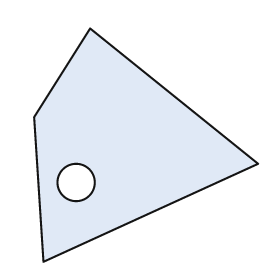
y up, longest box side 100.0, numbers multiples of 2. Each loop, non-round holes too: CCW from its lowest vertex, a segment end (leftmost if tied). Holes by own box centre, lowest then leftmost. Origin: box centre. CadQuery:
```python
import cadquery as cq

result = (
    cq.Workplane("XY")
    .moveTo(-44.0, -50.0)
    .lineTo(48.0, -8.0)
    .lineTo(-24.0, 50.0)
    .lineTo(-48.0, 12.0)
    .close()
    .moveTo(-30.0, -16.0)
    .circle(8.0)
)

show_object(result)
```